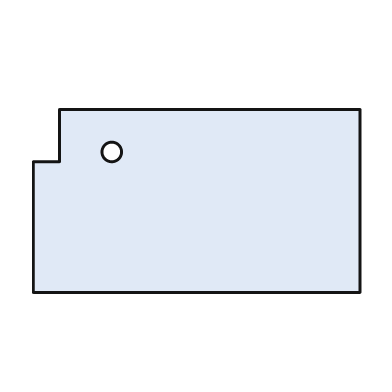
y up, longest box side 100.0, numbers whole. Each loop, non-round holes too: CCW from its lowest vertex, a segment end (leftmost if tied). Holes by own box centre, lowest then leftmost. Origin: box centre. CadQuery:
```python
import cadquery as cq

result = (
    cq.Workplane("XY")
    .moveTo(-50.0, -28.0)
    .lineTo(50.0, -28.0)
    .lineTo(50.0, 28.0)
    .lineTo(-42.0, 28.0)
    .lineTo(-42.0, 12.0)
    .lineTo(-50.0, 12.0)
    .close()
    .moveTo(-26.0, 15.0)
    .circle(3.0)
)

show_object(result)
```